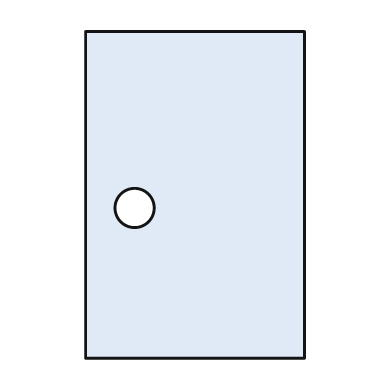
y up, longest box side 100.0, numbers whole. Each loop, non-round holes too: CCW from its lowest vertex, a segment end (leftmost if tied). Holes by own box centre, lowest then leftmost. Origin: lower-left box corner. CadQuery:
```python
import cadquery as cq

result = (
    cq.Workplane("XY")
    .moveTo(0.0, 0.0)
    .lineTo(67.0, 0.0)
    .lineTo(67.0, 100.0)
    .lineTo(0.0, 100.0)
    .close()
    .moveTo(15.0, 46.0)
    .circle(6.0)
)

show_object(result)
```